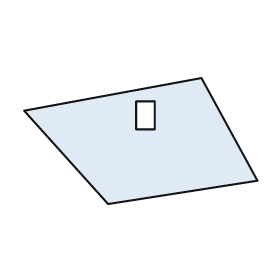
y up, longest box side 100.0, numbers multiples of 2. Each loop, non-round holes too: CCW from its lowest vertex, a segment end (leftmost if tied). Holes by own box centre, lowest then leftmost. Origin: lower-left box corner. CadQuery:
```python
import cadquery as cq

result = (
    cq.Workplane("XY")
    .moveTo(36.0, 0.0)
    .lineTo(100.0, 10.0)
    .lineTo(76.0, 54.0)
    .lineTo(0.0, 40.0)
    .close()
    .moveTo(48.0, 32.0)
    .lineTo(56.0, 32.0)
    .lineTo(56.0, 44.0)
    .lineTo(48.0, 44.0)
    .close()
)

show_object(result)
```